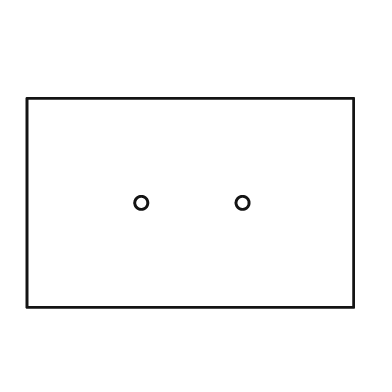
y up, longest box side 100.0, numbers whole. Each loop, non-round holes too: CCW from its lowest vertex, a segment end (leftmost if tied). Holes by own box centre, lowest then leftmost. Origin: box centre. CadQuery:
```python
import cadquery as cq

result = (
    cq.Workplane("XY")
    .moveTo(-50.0, -32.0)
    .lineTo(50.0, -32.0)
    .lineTo(50.0, 32.0)
    .lineTo(-50.0, 32.0)
    .close()
    .moveTo(-15.0, 0.0)
    .circle(2.0)
    .moveTo(16.0, 0.0)
    .circle(2.0)
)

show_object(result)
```